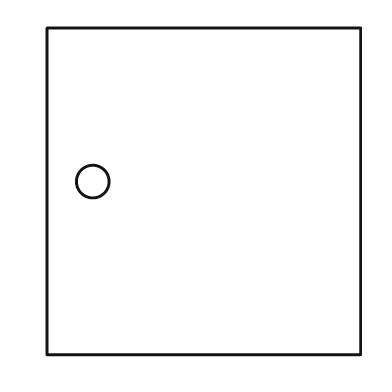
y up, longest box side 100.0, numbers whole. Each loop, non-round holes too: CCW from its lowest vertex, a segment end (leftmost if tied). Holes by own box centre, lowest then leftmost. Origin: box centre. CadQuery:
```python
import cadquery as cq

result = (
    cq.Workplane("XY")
    .moveTo(-48.0, -50.0)
    .lineTo(48.0, -50.0)
    .lineTo(48.0, 50.0)
    .lineTo(-48.0, 50.0)
    .close()
    .moveTo(-34.0, 3.0)
    .circle(5.0)
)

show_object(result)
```